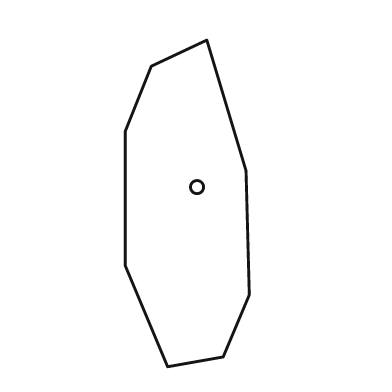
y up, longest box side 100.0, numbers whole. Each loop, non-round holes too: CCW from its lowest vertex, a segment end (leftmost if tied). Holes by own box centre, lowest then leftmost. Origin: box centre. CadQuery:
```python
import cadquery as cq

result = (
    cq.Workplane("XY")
    .moveTo(-6.0, -50.0)
    .lineTo(11.0, -47.0)
    .lineTo(19.0, -28.0)
    .lineTo(18.0, 10.0)
    .lineTo(6.0, 50.0)
    .lineTo(-11.0, 42.0)
    .lineTo(-19.0, 22.0)
    .lineTo(-19.0, -19.0)
    .close()
    .moveTo(3.0, 5.0)
    .circle(2.0)
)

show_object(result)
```